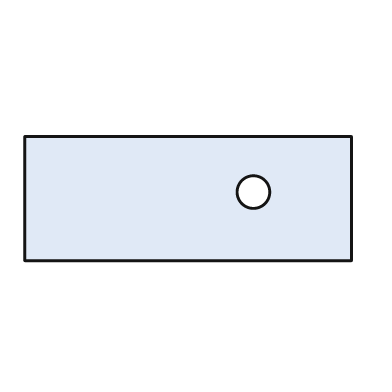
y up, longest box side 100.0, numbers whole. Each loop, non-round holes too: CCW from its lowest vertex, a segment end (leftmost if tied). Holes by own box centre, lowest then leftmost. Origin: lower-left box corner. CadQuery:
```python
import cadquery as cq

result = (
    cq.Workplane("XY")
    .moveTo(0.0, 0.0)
    .lineTo(100.0, 0.0)
    .lineTo(100.0, 38.0)
    .lineTo(0.0, 38.0)
    .close()
    .moveTo(70.0, 21.0)
    .circle(5.0)
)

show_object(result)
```